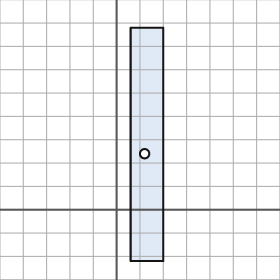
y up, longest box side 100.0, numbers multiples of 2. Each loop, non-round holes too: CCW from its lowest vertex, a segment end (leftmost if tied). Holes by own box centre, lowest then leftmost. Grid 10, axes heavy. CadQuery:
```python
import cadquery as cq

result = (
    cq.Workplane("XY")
    .moveTo(6.0, -22.0)
    .lineTo(20.0, -22.0)
    .lineTo(20.0, 78.0)
    .lineTo(6.0, 78.0)
    .close()
    .moveTo(12.0, 24.0)
    .circle(2.0)
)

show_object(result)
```